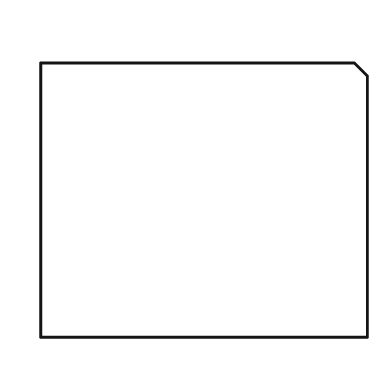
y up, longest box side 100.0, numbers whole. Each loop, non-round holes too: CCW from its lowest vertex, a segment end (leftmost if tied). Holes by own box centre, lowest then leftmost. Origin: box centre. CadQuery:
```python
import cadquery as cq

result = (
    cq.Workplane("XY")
    .moveTo(-50.0, -42.0)
    .lineTo(50.0, -42.0)
    .lineTo(50.0, 38.0)
    .lineTo(46.0, 42.0)
    .lineTo(-50.0, 42.0)
    .close()
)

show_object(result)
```